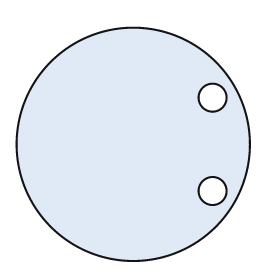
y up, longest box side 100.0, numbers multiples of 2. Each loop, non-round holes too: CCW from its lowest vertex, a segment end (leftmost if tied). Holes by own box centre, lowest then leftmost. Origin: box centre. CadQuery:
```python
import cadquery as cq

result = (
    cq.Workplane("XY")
    .moveTo(0.0, 0.0)
    .circle(50.0)
    .moveTo(34.0, -20.0)
    .circle(6.0)
    .moveTo(34.0, 20.0)
    .circle(6.0)
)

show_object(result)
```